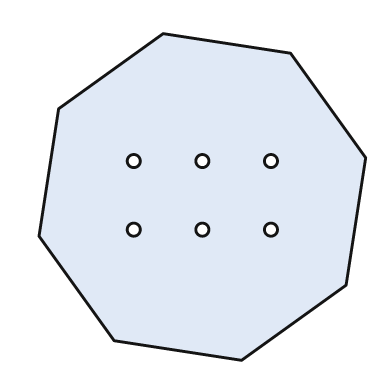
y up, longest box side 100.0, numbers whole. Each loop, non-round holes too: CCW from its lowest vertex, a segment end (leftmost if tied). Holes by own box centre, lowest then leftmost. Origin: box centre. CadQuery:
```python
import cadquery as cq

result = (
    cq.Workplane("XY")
    .moveTo(12.0, -50.0)
    .lineTo(44.0, -27.0)
    .lineTo(50.0, 12.0)
    .lineTo(27.0, 44.0)
    .lineTo(-12.0, 50.0)
    .lineTo(-44.0, 27.0)
    .lineTo(-50.0, -12.0)
    .lineTo(-27.0, -44.0)
    .close()
    .moveTo(-21.0, -10.0)
    .circle(2.0)
    .moveTo(0.0, -10.0)
    .circle(2.0)
    .moveTo(21.0, -10.0)
    .circle(2.0)
    .moveTo(-21.0, 11.0)
    .circle(2.0)
    .moveTo(0.0, 11.0)
    .circle(2.0)
    .moveTo(21.0, 11.0)
    .circle(2.0)
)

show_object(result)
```